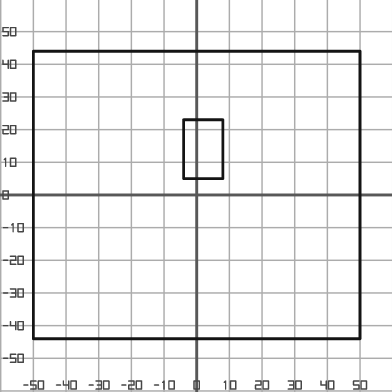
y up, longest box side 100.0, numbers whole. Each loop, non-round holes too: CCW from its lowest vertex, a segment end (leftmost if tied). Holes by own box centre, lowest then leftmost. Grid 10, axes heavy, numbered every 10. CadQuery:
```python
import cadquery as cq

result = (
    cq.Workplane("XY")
    .moveTo(-50.0, -44.0)
    .lineTo(50.0, -44.0)
    .lineTo(50.0, 44.0)
    .lineTo(-50.0, 44.0)
    .close()
    .moveTo(-4.0, 5.0)
    .lineTo(8.0, 5.0)
    .lineTo(8.0, 23.0)
    .lineTo(-4.0, 23.0)
    .close()
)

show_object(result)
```